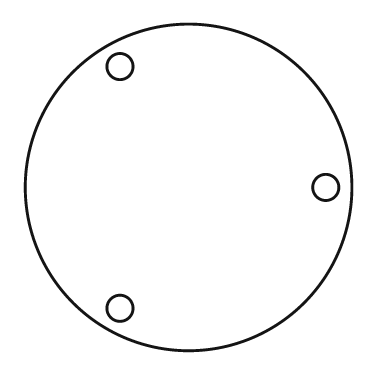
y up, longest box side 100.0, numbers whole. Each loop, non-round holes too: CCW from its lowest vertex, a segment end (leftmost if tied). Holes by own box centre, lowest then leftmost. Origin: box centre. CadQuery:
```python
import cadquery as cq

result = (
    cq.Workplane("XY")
    .moveTo(0.0, 0.0)
    .circle(50.0)
    .moveTo(-21.0, -37.0)
    .circle(4.0)
    .moveTo(42.0, 0.0)
    .circle(4.0)
    .moveTo(-21.0, 37.0)
    .circle(4.0)
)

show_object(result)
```